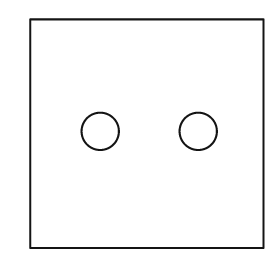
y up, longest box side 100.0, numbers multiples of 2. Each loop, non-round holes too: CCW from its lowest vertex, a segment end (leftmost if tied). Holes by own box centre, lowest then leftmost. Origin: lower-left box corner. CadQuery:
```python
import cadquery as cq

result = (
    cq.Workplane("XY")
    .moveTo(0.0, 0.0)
    .lineTo(100.0, 0.0)
    .lineTo(100.0, 98.0)
    .lineTo(0.0, 98.0)
    .close()
    .moveTo(30.0, 50.0)
    .circle(8.0)
    .moveTo(72.0, 50.0)
    .circle(8.0)
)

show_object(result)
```